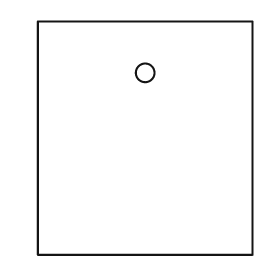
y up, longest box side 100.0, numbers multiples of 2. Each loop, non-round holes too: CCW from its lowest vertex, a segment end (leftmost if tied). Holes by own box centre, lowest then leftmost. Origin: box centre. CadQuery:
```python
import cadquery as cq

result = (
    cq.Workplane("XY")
    .moveTo(-46.0, -50.0)
    .lineTo(46.0, -50.0)
    .lineTo(46.0, 50.0)
    .lineTo(-46.0, 50.0)
    .close()
    .moveTo(0.0, 28.0)
    .circle(4.0)
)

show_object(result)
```